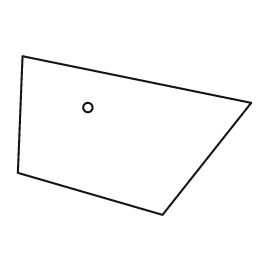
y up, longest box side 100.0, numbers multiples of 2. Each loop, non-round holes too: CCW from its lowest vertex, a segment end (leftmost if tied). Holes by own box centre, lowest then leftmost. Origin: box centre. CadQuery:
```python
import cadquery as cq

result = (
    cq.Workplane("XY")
    .moveTo(12.0, -34.0)
    .lineTo(50.0, 14.0)
    .lineTo(-48.0, 34.0)
    .lineTo(-50.0, -16.0)
    .close()
    .moveTo(-20.0, 12.0)
    .circle(2.0)
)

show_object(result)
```